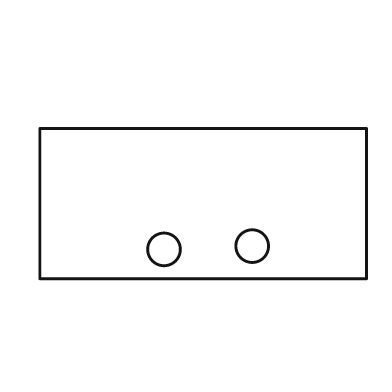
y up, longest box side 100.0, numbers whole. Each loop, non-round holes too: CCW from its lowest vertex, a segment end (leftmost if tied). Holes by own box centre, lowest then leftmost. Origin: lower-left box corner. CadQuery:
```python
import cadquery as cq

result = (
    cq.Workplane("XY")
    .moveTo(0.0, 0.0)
    .lineTo(100.0, 0.0)
    .lineTo(100.0, 46.0)
    .lineTo(0.0, 46.0)
    .close()
    .moveTo(38.0, 9.0)
    .circle(5.0)
    .moveTo(65.0, 10.0)
    .circle(5.0)
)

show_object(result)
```